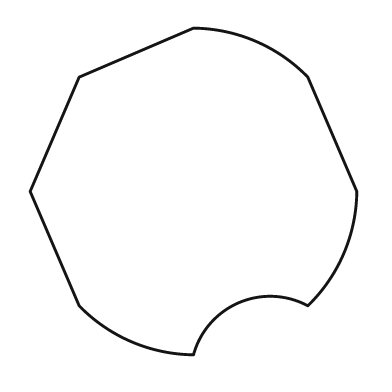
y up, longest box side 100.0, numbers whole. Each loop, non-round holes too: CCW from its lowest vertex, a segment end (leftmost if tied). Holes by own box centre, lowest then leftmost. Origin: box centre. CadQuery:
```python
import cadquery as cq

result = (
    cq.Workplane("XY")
    .moveTo(0.0, -50.0)
    .threePointArc((14.0, -34.0), (35.0, -35.0))
    .threePointArc((46.0, -19.0), (50.0, 0.0))
    .lineTo(35.0, 35.0)
    .threePointArc((19.0, 46.0), (0.0, 50.0))
    .lineTo(-35.0, 35.0)
    .lineTo(-50.0, 0.0)
    .lineTo(-35.0, -35.0)
    .threePointArc((-19.0, -46.0), (0.0, -50.0))
    .close()
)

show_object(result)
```